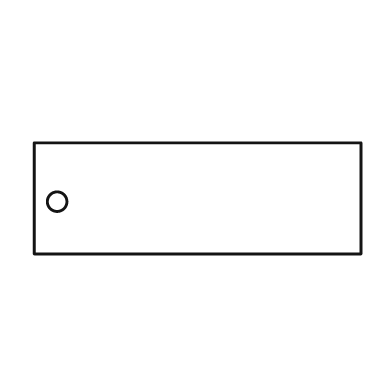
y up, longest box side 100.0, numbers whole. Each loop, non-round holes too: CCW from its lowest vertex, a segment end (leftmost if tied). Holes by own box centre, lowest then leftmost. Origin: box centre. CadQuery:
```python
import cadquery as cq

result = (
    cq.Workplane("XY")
    .moveTo(-50.0, -17.0)
    .lineTo(50.0, -17.0)
    .lineTo(50.0, 17.0)
    .lineTo(-50.0, 17.0)
    .close()
    .moveTo(-43.0, -1.0)
    .circle(3.0)
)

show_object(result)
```